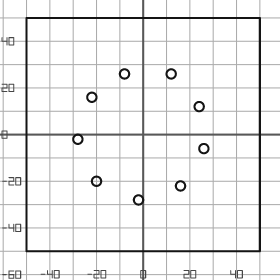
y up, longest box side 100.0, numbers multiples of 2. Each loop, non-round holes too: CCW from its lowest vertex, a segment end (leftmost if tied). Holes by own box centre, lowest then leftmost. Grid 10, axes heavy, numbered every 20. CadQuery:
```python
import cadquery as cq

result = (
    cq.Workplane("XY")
    .moveTo(-50.0, -50.0)
    .lineTo(50.0, -50.0)
    .lineTo(50.0, 50.0)
    .lineTo(-50.0, 50.0)
    .close()
    .moveTo(-2.0, -28.0)
    .circle(2.0)
    .moveTo(16.0, -22.0)
    .circle(2.0)
    .moveTo(-20.0, -20.0)
    .circle(2.0)
    .moveTo(26.0, -6.0)
    .circle(2.0)
    .moveTo(-28.0, -2.0)
    .circle(2.0)
    .moveTo(24.0, 12.0)
    .circle(2.0)
    .moveTo(-22.0, 16.0)
    .circle(2.0)
    .moveTo(-8.0, 26.0)
    .circle(2.0)
    .moveTo(12.0, 26.0)
    .circle(2.0)
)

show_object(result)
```